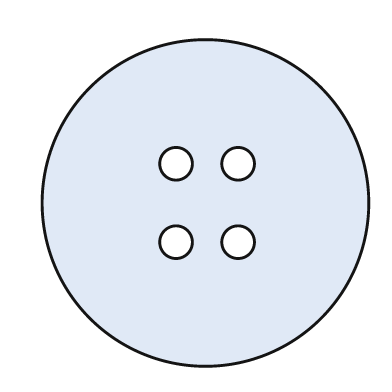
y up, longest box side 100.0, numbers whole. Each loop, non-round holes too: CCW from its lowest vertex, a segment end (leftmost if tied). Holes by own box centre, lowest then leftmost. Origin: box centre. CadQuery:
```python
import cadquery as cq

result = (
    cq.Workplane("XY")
    .moveTo(0.0, 0.0)
    .circle(50.0)
    .moveTo(-9.0, -12.0)
    .circle(5.0)
    .moveTo(10.0, -12.0)
    .circle(5.0)
    .moveTo(-9.0, 12.0)
    .circle(5.0)
    .moveTo(10.0, 12.0)
    .circle(5.0)
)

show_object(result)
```